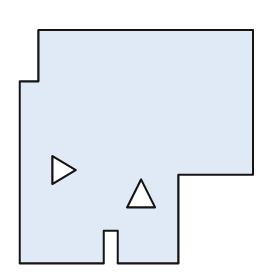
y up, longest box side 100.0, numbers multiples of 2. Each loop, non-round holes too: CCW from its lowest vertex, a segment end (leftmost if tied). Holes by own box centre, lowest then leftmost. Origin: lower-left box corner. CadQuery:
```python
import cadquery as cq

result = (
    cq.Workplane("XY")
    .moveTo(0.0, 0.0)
    .lineTo(36.0, 0.0)
    .lineTo(36.0, 14.0)
    .lineTo(42.0, 14.0)
    .lineTo(42.0, 0.0)
    .lineTo(68.0, 0.0)
    .lineTo(68.0, 38.0)
    .lineTo(100.0, 38.0)
    .lineTo(100.0, 100.0)
    .lineTo(8.0, 100.0)
    .lineTo(8.0, 78.0)
    .lineTo(0.0, 78.0)
    .close()
    .moveTo(46.0, 24.0)
    .lineTo(58.0, 24.0)
    .lineTo(52.0, 36.0)
    .close()
    .moveTo(14.0, 34.0)
    .lineTo(24.0, 40.0)
    .lineTo(14.0, 46.0)
    .close()
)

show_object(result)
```